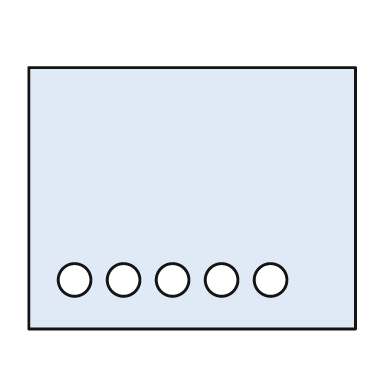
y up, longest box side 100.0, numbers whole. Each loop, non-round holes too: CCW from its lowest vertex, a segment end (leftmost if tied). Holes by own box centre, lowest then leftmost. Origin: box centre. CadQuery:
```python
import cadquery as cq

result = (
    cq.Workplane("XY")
    .moveTo(-50.0, -40.0)
    .lineTo(50.0, -40.0)
    .lineTo(50.0, 40.0)
    .lineTo(-50.0, 40.0)
    .close()
    .moveTo(-36.0, -25.0)
    .circle(5.0)
    .moveTo(-21.0, -25.0)
    .circle(5.0)
    .moveTo(-6.0, -25.0)
    .circle(5.0)
    .moveTo(9.0, -25.0)
    .circle(5.0)
    .moveTo(24.0, -25.0)
    .circle(5.0)
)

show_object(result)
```